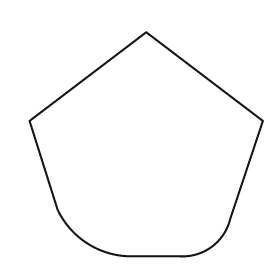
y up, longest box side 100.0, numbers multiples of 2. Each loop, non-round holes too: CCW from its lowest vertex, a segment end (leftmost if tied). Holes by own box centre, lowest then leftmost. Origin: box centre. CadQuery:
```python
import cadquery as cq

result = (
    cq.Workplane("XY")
    .moveTo(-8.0, -48.0)
    .lineTo(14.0, -48.0)
    .threePointArc((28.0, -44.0), (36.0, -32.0))
    .lineTo(50.0, 10.0)
    .lineTo(0.0, 48.0)
    .lineTo(-50.0, 10.0)
    .lineTo(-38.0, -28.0)
    .threePointArc((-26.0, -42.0), (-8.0, -48.0))
    .close()
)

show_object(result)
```